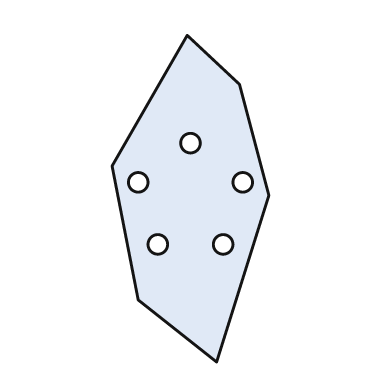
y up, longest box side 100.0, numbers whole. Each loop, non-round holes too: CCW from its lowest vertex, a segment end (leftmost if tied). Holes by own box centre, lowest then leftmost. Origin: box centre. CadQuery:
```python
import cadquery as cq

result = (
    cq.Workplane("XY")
    .moveTo(8.0, -50.0)
    .lineTo(24.0, 1.0)
    .lineTo(15.0, 35.0)
    .lineTo(-1.0, 50.0)
    .lineTo(-24.0, 10.0)
    .lineTo(-16.0, -31.0)
    .close()
    .moveTo(-10.0, -14.0)
    .circle(3.0)
    .moveTo(10.0, -14.0)
    .circle(3.0)
    .moveTo(-16.0, 5.0)
    .circle(3.0)
    .moveTo(16.0, 5.0)
    .circle(3.0)
    .moveTo(0.0, 17.0)
    .circle(3.0)
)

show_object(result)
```